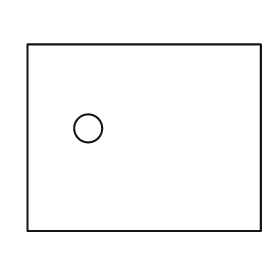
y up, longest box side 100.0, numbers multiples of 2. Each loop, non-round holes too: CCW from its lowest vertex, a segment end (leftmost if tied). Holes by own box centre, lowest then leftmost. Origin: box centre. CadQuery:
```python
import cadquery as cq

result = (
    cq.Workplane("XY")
    .moveTo(-50.0, -40.0)
    .lineTo(50.0, -40.0)
    .lineTo(50.0, 40.0)
    .lineTo(-50.0, 40.0)
    .close()
    .moveTo(-24.0, 4.0)
    .circle(6.0)
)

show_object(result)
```